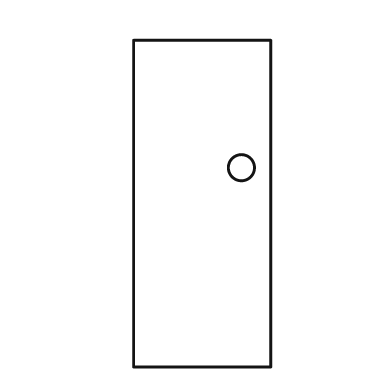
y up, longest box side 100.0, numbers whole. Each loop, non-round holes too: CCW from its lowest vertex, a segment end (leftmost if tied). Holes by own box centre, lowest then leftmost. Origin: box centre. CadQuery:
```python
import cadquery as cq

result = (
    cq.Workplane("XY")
    .moveTo(-21.0, -50.0)
    .lineTo(21.0, -50.0)
    .lineTo(21.0, 50.0)
    .lineTo(-21.0, 50.0)
    .close()
    .moveTo(12.0, 11.0)
    .circle(4.0)
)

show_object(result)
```